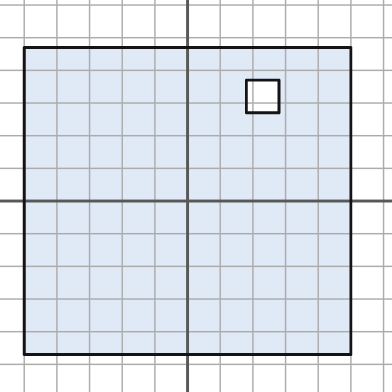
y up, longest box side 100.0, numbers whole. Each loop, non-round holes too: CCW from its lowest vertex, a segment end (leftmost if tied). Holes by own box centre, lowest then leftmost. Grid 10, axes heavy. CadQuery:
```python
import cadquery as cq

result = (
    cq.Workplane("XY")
    .moveTo(-50.0, -47.0)
    .lineTo(50.0, -47.0)
    .lineTo(50.0, 47.0)
    .lineTo(-50.0, 47.0)
    .close()
    .moveTo(18.0, 27.0)
    .lineTo(28.0, 27.0)
    .lineTo(28.0, 37.0)
    .lineTo(18.0, 37.0)
    .close()
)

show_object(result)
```